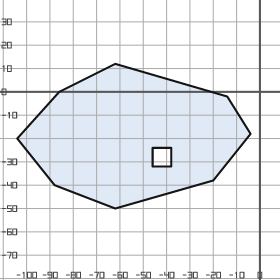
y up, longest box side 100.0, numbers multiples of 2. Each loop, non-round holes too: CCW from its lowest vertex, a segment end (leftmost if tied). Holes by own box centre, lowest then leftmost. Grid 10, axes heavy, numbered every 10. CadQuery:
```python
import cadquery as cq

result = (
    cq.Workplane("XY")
    .moveTo(-62.0, -50.0)
    .lineTo(-20.0, -38.0)
    .lineTo(-4.0, -18.0)
    .lineTo(-14.0, -2.0)
    .lineTo(-62.0, 12.0)
    .lineTo(-86.0, 0.0)
    .lineTo(-104.0, -20.0)
    .lineTo(-88.0, -40.0)
    .close()
    .moveTo(-46.0, -32.0)
    .lineTo(-38.0, -32.0)
    .lineTo(-38.0, -24.0)
    .lineTo(-46.0, -24.0)
    .close()
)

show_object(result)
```